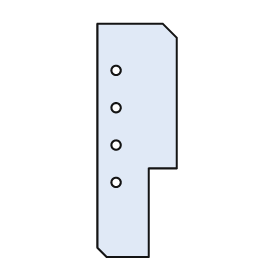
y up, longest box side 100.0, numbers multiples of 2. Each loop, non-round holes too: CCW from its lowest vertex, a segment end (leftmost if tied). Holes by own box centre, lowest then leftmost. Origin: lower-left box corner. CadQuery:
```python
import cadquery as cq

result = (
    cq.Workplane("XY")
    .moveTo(4.0, 0.0)
    .lineTo(22.0, 0.0)
    .lineTo(22.0, 38.0)
    .lineTo(34.0, 38.0)
    .lineTo(34.0, 94.0)
    .lineTo(28.0, 100.0)
    .lineTo(0.0, 100.0)
    .lineTo(0.0, 4.0)
    .close()
    .moveTo(8.0, 32.0)
    .circle(2.0)
    .moveTo(8.0, 48.0)
    .circle(2.0)
    .moveTo(8.0, 64.0)
    .circle(2.0)
    .moveTo(8.0, 80.0)
    .circle(2.0)
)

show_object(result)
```